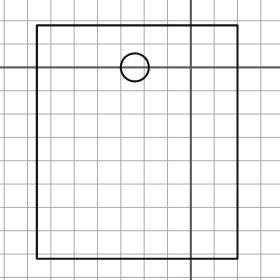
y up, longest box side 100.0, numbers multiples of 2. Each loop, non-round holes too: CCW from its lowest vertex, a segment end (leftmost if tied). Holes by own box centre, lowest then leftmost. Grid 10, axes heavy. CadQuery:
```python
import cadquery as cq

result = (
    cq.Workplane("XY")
    .moveTo(-66.0, -82.0)
    .lineTo(20.0, -82.0)
    .lineTo(20.0, 18.0)
    .lineTo(-66.0, 18.0)
    .close()
    .moveTo(-24.0, 0.0)
    .circle(6.0)
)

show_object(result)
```